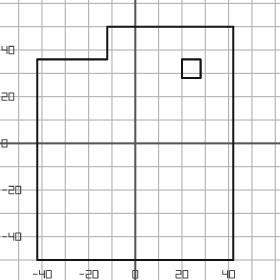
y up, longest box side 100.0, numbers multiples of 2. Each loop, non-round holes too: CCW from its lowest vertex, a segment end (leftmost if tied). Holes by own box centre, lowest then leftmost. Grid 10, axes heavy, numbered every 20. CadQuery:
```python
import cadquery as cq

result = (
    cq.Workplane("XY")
    .moveTo(-42.0, -50.0)
    .lineTo(42.0, -50.0)
    .lineTo(42.0, 50.0)
    .lineTo(-12.0, 50.0)
    .lineTo(-12.0, 36.0)
    .lineTo(-42.0, 36.0)
    .close()
    .moveTo(20.0, 28.0)
    .lineTo(28.0, 28.0)
    .lineTo(28.0, 36.0)
    .lineTo(20.0, 36.0)
    .close()
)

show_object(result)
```